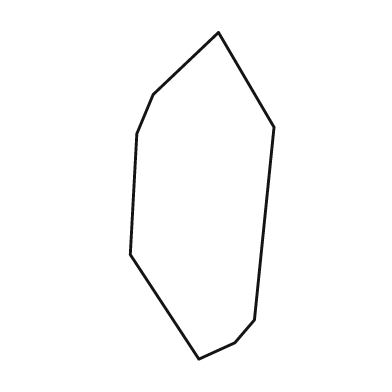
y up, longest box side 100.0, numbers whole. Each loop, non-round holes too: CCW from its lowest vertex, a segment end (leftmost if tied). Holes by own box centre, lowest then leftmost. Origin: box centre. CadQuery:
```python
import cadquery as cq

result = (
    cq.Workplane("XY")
    .moveTo(-1.0, -50.0)
    .lineTo(10.0, -45.0)
    .lineTo(16.0, -38.0)
    .lineTo(22.0, 21.0)
    .lineTo(5.0, 50.0)
    .lineTo(-15.0, 31.0)
    .lineTo(-20.0, 19.0)
    .lineTo(-22.0, -18.0)
    .close()
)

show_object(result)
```